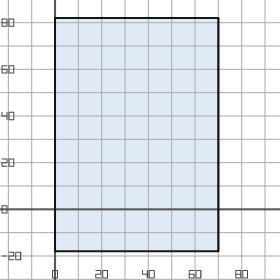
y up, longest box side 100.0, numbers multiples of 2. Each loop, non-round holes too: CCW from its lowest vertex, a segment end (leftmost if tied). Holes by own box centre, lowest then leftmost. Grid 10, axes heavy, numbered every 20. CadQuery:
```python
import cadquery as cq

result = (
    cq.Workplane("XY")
    .moveTo(0.0, -18.0)
    .lineTo(70.0, -18.0)
    .lineTo(70.0, 82.0)
    .lineTo(0.0, 82.0)
    .close()
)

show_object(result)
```